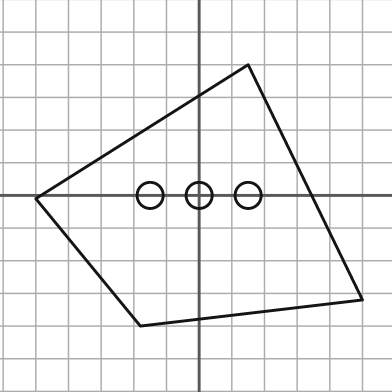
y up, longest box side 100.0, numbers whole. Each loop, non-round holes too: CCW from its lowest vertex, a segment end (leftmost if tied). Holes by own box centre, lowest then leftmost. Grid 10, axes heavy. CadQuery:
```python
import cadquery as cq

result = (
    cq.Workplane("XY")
    .moveTo(-18.0, -40.0)
    .lineTo(50.0, -32.0)
    .lineTo(15.0, 40.0)
    .lineTo(-50.0, -1.0)
    .close()
    .moveTo(-15.0, 0.0)
    .circle(4.0)
    .moveTo(0.0, 0.0)
    .circle(4.0)
    .moveTo(15.0, 0.0)
    .circle(4.0)
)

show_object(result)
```